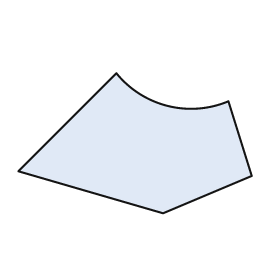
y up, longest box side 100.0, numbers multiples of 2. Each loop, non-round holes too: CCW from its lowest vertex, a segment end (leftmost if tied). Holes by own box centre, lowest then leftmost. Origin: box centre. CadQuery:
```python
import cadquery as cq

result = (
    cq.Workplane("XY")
    .moveTo(12.0, -30.0)
    .lineTo(50.0, -14.0)
    .lineTo(40.0, 18.0)
    .threePointArc((14.0, 16.0), (-8.0, 30.0))
    .lineTo(-50.0, -12.0)
    .close()
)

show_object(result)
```